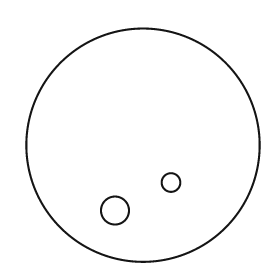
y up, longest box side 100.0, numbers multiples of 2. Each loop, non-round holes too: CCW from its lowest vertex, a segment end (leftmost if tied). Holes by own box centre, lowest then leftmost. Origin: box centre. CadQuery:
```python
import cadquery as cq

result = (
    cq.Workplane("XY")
    .moveTo(0.0, 0.0)
    .circle(50.0)
    .moveTo(-12.0, -28.0)
    .circle(6.0)
    .moveTo(12.0, -16.0)
    .circle(4.0)
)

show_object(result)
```